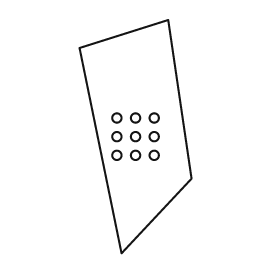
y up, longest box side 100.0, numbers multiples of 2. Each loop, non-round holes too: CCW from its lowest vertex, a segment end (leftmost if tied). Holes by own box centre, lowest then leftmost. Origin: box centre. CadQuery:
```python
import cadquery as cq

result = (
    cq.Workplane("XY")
    .moveTo(-6.0, -50.0)
    .lineTo(24.0, -18.0)
    .lineTo(14.0, 50.0)
    .lineTo(-24.0, 38.0)
    .close()
    .moveTo(-8.0, -8.0)
    .circle(2.0)
    .moveTo(0.0, -8.0)
    .circle(2.0)
    .moveTo(8.0, -8.0)
    .circle(2.0)
    .moveTo(-8.0, 0.0)
    .circle(2.0)
    .moveTo(0.0, 0.0)
    .circle(2.0)
    .moveTo(8.0, 0.0)
    .circle(2.0)
    .moveTo(-8.0, 8.0)
    .circle(2.0)
    .moveTo(0.0, 8.0)
    .circle(2.0)
    .moveTo(8.0, 8.0)
    .circle(2.0)
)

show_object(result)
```